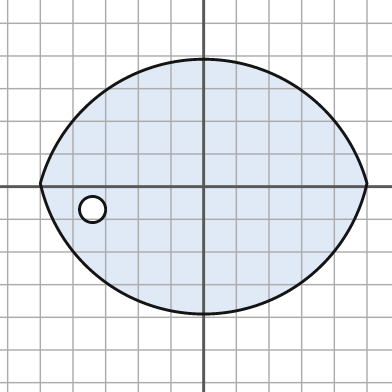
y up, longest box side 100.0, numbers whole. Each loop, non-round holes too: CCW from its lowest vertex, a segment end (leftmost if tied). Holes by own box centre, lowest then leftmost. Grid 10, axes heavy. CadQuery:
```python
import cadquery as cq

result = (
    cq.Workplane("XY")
    .moveTo(-50.0, 1.0)
    .threePointArc((0.0, -39.0), (50.0, 1.0))
    .threePointArc((0.0, 39.0), (-50.0, 1.0))
    .close()
    .moveTo(-34.0, -7.0)
    .circle(4.0)
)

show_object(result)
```